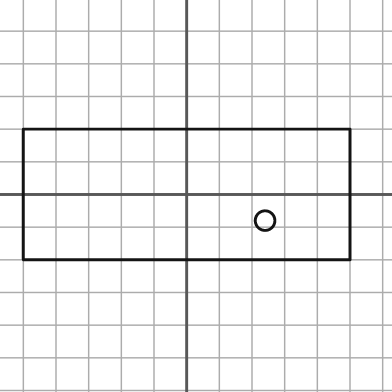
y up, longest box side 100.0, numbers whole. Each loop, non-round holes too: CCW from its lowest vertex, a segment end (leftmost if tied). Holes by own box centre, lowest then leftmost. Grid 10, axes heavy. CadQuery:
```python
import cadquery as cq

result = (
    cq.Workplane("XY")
    .moveTo(-50.0, -20.0)
    .lineTo(50.0, -20.0)
    .lineTo(50.0, 20.0)
    .lineTo(-50.0, 20.0)
    .close()
    .moveTo(24.0, -8.0)
    .circle(3.0)
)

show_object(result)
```